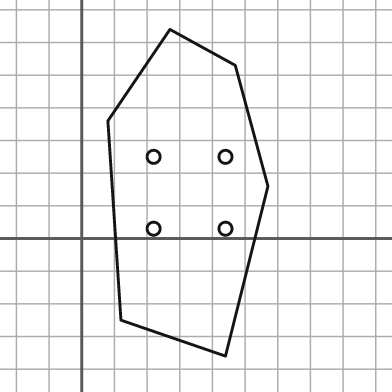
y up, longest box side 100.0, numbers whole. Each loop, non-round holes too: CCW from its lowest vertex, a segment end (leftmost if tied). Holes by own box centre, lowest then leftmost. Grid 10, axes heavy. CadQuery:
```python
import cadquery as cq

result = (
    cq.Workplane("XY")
    .moveTo(44.0, -36.0)
    .lineTo(57.0, 16.0)
    .lineTo(47.0, 53.0)
    .lineTo(27.0, 64.0)
    .lineTo(8.0, 36.0)
    .lineTo(12.0, -25.0)
    .close()
    .moveTo(22.0, 3.0)
    .circle(2.0)
    .moveTo(44.0, 3.0)
    .circle(2.0)
    .moveTo(22.0, 25.0)
    .circle(2.0)
    .moveTo(44.0, 25.0)
    .circle(2.0)
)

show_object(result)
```